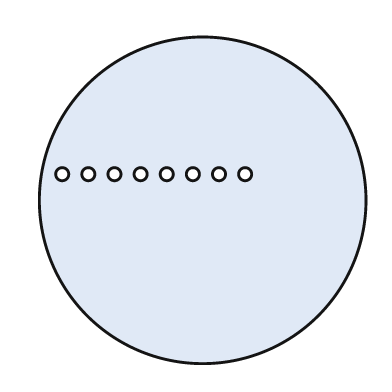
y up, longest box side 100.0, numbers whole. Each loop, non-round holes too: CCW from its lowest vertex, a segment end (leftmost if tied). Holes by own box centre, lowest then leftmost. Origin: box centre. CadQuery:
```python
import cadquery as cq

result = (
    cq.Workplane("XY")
    .moveTo(0.0, 0.0)
    .circle(50.0)
    .moveTo(-43.0, 8.0)
    .circle(2.0)
    .moveTo(-35.0, 8.0)
    .circle(2.0)
    .moveTo(-27.0, 8.0)
    .circle(2.0)
    .moveTo(-19.0, 8.0)
    .circle(2.0)
    .moveTo(-11.0, 8.0)
    .circle(2.0)
    .moveTo(-3.0, 8.0)
    .circle(2.0)
    .moveTo(5.0, 8.0)
    .circle(2.0)
    .moveTo(13.0, 8.0)
    .circle(2.0)
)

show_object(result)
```